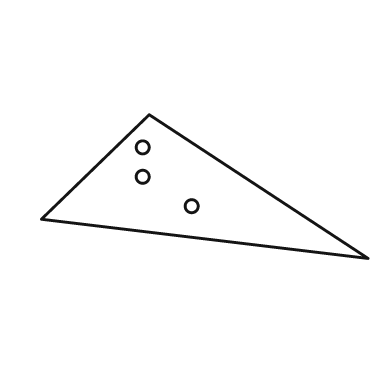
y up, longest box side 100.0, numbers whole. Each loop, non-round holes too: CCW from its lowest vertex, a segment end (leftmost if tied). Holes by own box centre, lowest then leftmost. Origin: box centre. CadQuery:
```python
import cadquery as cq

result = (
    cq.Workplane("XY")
    .moveTo(50.0, -22.0)
    .lineTo(-17.0, 22.0)
    .lineTo(-50.0, -10.0)
    .close()
    .moveTo(-4.0, -6.0)
    .circle(2.0)
    .moveTo(-19.0, 3.0)
    .circle(2.0)
    .moveTo(-19.0, 12.0)
    .circle(2.0)
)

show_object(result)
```